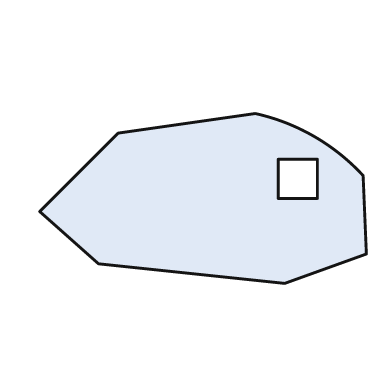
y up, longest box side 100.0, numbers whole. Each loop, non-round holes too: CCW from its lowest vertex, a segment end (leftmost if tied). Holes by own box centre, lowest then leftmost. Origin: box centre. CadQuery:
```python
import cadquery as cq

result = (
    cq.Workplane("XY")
    .moveTo(25.0, -26.0)
    .lineTo(50.0, -17.0)
    .lineTo(49.0, 7.0)
    .threePointArc((34.0, 19.0), (16.0, 26.0))
    .lineTo(-26.0, 20.0)
    .lineTo(-50.0, -4.0)
    .lineTo(-32.0, -20.0)
    .close()
    .moveTo(23.0, 0.0)
    .lineTo(35.0, 0.0)
    .lineTo(35.0, 12.0)
    .lineTo(23.0, 12.0)
    .close()
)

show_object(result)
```